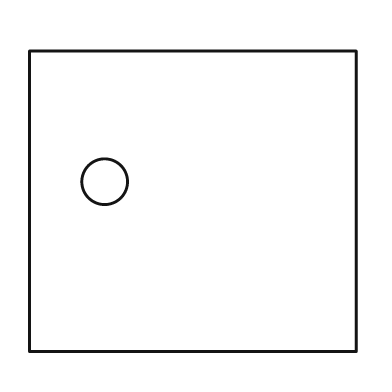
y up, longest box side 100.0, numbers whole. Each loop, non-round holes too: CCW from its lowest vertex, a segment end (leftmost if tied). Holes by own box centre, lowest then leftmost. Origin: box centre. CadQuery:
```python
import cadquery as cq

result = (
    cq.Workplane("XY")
    .moveTo(-50.0, -46.0)
    .lineTo(50.0, -46.0)
    .lineTo(50.0, 46.0)
    .lineTo(-50.0, 46.0)
    .close()
    .moveTo(-27.0, 6.0)
    .circle(7.0)
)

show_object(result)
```